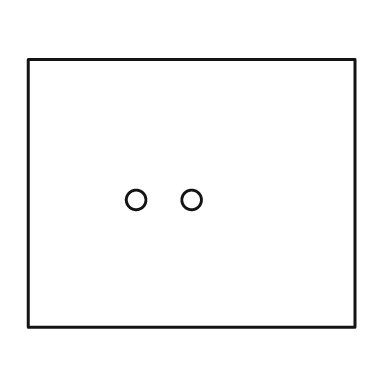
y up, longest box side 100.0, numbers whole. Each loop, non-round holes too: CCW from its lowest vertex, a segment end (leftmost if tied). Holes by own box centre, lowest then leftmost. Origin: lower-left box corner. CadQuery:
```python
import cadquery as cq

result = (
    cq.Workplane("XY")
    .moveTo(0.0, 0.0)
    .lineTo(100.0, 0.0)
    .lineTo(100.0, 82.0)
    .lineTo(0.0, 82.0)
    .close()
    .moveTo(33.0, 39.0)
    .circle(3.0)
    .moveTo(50.0, 39.0)
    .circle(3.0)
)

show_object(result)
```